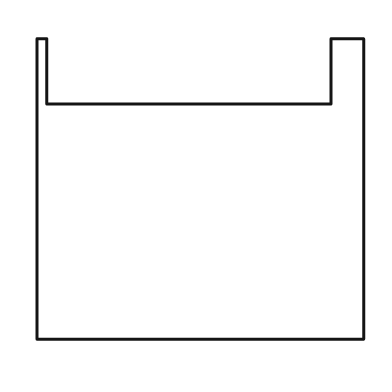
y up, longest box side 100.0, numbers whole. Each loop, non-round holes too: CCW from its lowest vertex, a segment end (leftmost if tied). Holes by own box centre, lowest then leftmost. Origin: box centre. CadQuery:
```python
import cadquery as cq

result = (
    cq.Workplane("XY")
    .moveTo(-50.0, -46.0)
    .lineTo(50.0, -46.0)
    .lineTo(50.0, 46.0)
    .lineTo(40.0, 46.0)
    .lineTo(40.0, 26.0)
    .lineTo(-47.0, 26.0)
    .lineTo(-47.0, 46.0)
    .lineTo(-50.0, 46.0)
    .close()
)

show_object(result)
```